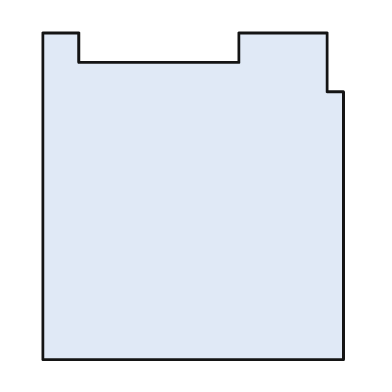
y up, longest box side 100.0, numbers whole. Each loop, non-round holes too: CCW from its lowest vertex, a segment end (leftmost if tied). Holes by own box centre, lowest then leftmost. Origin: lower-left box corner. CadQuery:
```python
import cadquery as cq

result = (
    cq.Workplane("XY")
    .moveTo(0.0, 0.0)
    .lineTo(92.0, 0.0)
    .lineTo(92.0, 82.0)
    .lineTo(87.0, 82.0)
    .lineTo(87.0, 100.0)
    .lineTo(60.0, 100.0)
    .lineTo(60.0, 91.0)
    .lineTo(11.0, 91.0)
    .lineTo(11.0, 100.0)
    .lineTo(0.0, 100.0)
    .close()
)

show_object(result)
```